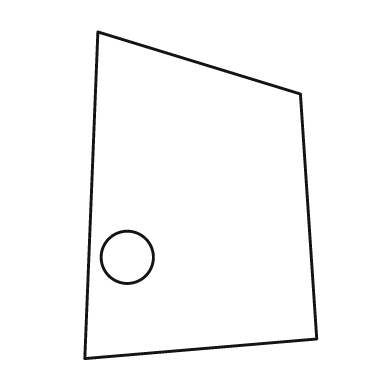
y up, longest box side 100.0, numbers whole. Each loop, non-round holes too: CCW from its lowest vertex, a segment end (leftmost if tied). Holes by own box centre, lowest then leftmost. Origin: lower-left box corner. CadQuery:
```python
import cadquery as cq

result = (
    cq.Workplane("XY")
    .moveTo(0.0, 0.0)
    .lineTo(71.0, 6.0)
    .lineTo(66.0, 81.0)
    .lineTo(4.0, 100.0)
    .close()
    .moveTo(13.0, 31.0)
    .circle(8.0)
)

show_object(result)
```